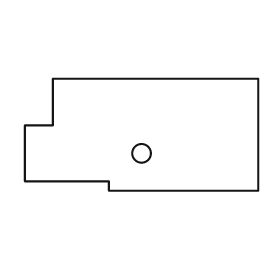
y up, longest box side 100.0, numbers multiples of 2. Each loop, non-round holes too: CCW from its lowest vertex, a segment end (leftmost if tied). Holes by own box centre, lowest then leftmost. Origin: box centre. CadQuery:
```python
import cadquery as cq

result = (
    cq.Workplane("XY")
    .moveTo(-14.0, -24.0)
    .lineTo(50.0, -24.0)
    .lineTo(50.0, 24.0)
    .lineTo(-38.0, 24.0)
    .lineTo(-38.0, 4.0)
    .lineTo(-50.0, 4.0)
    .lineTo(-50.0, -20.0)
    .lineTo(-14.0, -20.0)
    .close()
    .moveTo(0.0, -8.0)
    .circle(4.0)
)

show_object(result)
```